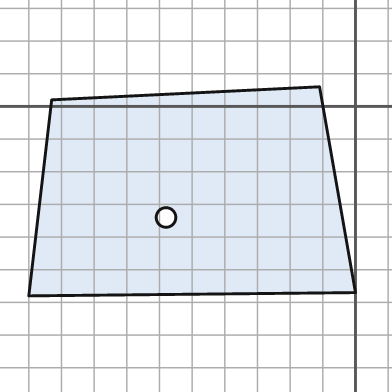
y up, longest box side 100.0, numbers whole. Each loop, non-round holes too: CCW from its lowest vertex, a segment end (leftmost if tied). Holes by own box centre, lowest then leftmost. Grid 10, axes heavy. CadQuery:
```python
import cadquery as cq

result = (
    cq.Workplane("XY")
    .moveTo(-100.0, -58.0)
    .lineTo(0.0, -57.0)
    .lineTo(-11.0, 6.0)
    .lineTo(-93.0, 2.0)
    .close()
    .moveTo(-58.0, -34.0)
    .circle(3.0)
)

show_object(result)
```